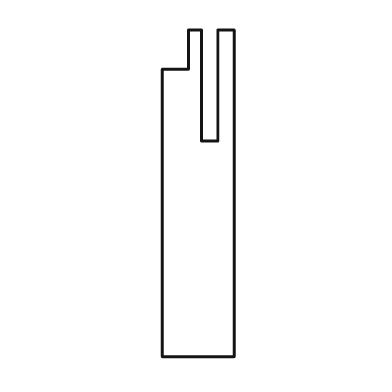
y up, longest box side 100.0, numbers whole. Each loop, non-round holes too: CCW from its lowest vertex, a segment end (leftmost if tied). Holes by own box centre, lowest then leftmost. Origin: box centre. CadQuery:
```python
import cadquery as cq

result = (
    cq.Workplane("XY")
    .moveTo(-11.0, -50.0)
    .lineTo(11.0, -50.0)
    .lineTo(11.0, 50.0)
    .lineTo(6.0, 50.0)
    .lineTo(6.0, 16.0)
    .lineTo(1.0, 16.0)
    .lineTo(1.0, 50.0)
    .lineTo(-3.0, 50.0)
    .lineTo(-3.0, 38.0)
    .lineTo(-11.0, 38.0)
    .close()
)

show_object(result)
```